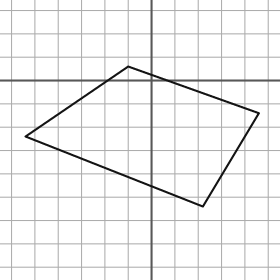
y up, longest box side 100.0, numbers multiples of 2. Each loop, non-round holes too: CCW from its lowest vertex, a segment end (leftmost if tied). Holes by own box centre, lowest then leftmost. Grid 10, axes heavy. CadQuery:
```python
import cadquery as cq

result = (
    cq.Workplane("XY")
    .moveTo(22.0, -54.0)
    .lineTo(46.0, -14.0)
    .lineTo(-10.0, 6.0)
    .lineTo(-54.0, -24.0)
    .close()
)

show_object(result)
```